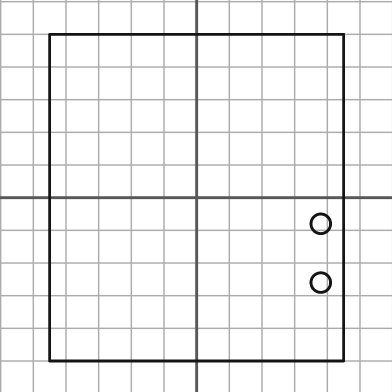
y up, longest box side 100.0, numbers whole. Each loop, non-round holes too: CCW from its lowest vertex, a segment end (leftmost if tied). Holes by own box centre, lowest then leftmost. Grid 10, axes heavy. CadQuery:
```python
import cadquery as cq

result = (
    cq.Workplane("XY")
    .moveTo(-45.0, -50.0)
    .lineTo(45.0, -50.0)
    .lineTo(45.0, 50.0)
    .lineTo(-45.0, 50.0)
    .close()
    .moveTo(38.0, -26.0)
    .circle(3.0)
    .moveTo(38.0, -8.0)
    .circle(3.0)
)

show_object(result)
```